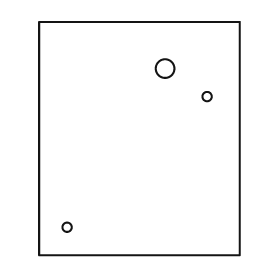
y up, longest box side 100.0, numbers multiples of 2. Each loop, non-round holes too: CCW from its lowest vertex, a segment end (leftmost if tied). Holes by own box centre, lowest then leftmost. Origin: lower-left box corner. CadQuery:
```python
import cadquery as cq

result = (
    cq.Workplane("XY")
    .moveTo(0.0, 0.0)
    .lineTo(86.0, 0.0)
    .lineTo(86.0, 100.0)
    .lineTo(0.0, 100.0)
    .close()
    .moveTo(12.0, 12.0)
    .circle(2.0)
    .moveTo(72.0, 68.0)
    .circle(2.0)
    .moveTo(54.0, 80.0)
    .circle(4.0)
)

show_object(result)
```